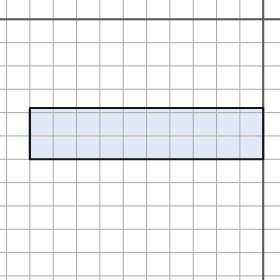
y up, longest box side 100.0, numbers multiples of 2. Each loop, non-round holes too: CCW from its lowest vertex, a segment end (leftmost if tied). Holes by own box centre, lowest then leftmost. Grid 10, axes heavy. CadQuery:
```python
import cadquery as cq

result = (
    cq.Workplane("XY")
    .moveTo(-100.0, -60.0)
    .lineTo(0.0, -60.0)
    .lineTo(0.0, -38.0)
    .lineTo(-100.0, -38.0)
    .close()
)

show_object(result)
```